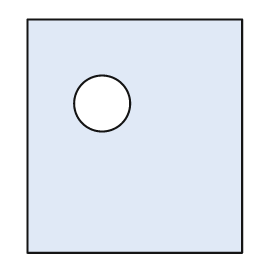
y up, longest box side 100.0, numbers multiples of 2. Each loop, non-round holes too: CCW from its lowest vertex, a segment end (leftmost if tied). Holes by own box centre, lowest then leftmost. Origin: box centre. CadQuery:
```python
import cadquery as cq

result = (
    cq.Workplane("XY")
    .moveTo(-46.0, -50.0)
    .lineTo(46.0, -50.0)
    .lineTo(46.0, 50.0)
    .lineTo(-46.0, 50.0)
    .close()
    .moveTo(-14.0, 14.0)
    .circle(12.0)
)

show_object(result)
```